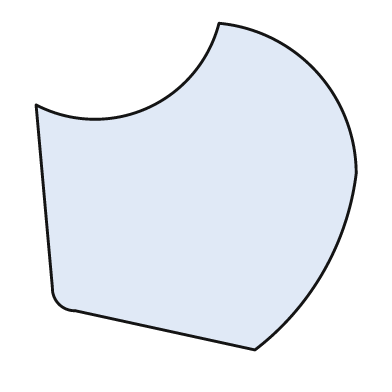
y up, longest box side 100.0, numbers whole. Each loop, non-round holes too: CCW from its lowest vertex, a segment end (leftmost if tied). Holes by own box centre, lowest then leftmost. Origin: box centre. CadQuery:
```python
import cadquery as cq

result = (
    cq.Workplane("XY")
    .moveTo(18.0, -50.0)
    .threePointArc((39.0, -26.0), (49.0, 4.0))
    .threePointArc((37.0, 35.0), (7.0, 50.0))
    .threePointArc((-15.0, 24.0), (-49.0, 25.0))
    .lineTo(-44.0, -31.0)
    .threePointArc((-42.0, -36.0), (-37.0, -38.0))
    .close()
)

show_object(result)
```